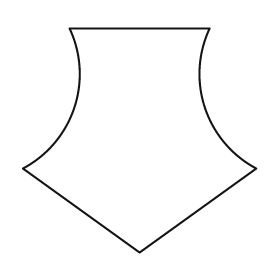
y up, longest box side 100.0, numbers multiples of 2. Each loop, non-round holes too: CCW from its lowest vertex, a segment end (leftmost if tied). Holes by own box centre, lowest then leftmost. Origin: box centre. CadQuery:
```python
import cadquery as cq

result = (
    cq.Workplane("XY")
    .moveTo(0.0, -48.0)
    .lineTo(50.0, -12.0)
    .threePointArc((28.0, 14.0), (30.0, 48.0))
    .lineTo(-30.0, 48.0)
    .threePointArc((-28.0, 14.0), (-50.0, -12.0))
    .close()
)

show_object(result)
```